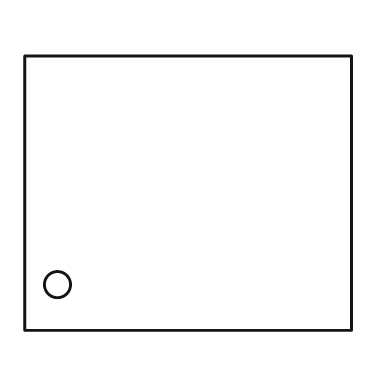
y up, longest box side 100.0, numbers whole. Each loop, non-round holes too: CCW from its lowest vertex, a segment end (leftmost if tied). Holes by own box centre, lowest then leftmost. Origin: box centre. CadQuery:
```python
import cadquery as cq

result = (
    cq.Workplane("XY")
    .moveTo(-50.0, -42.0)
    .lineTo(50.0, -42.0)
    .lineTo(50.0, 42.0)
    .lineTo(-50.0, 42.0)
    .close()
    .moveTo(-40.0, -28.0)
    .circle(4.0)
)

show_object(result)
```